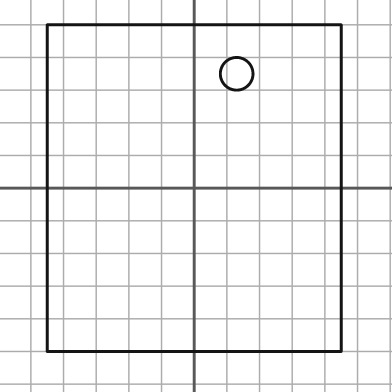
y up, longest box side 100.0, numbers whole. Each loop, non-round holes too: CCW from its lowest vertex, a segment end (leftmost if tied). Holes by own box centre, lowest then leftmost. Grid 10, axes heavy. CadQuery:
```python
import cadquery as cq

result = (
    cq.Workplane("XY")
    .moveTo(-45.0, -50.0)
    .lineTo(45.0, -50.0)
    .lineTo(45.0, 50.0)
    .lineTo(-45.0, 50.0)
    .close()
    .moveTo(13.0, 35.0)
    .circle(5.0)
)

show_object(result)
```